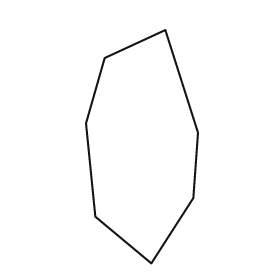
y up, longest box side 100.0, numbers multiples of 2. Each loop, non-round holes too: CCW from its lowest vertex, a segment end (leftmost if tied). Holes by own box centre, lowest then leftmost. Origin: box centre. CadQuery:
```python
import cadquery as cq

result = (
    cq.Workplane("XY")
    .moveTo(4.0, -50.0)
    .lineTo(22.0, -22.0)
    .lineTo(24.0, 6.0)
    .lineTo(10.0, 50.0)
    .lineTo(-16.0, 38.0)
    .lineTo(-24.0, 10.0)
    .lineTo(-20.0, -30.0)
    .close()
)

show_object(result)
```